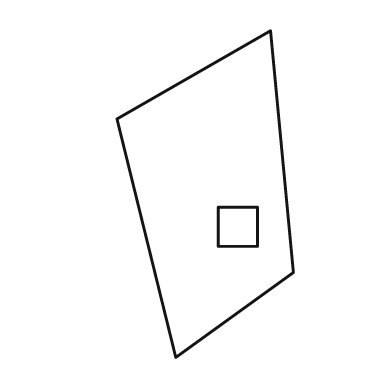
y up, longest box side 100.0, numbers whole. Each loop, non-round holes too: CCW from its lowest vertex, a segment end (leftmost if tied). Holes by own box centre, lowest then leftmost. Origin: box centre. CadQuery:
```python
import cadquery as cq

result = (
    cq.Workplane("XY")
    .moveTo(-9.0, -50.0)
    .lineTo(27.0, -24.0)
    .lineTo(20.0, 50.0)
    .lineTo(-27.0, 23.0)
    .close()
    .moveTo(4.0, -16.0)
    .lineTo(16.0, -16.0)
    .lineTo(16.0, -4.0)
    .lineTo(4.0, -4.0)
    .close()
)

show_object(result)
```